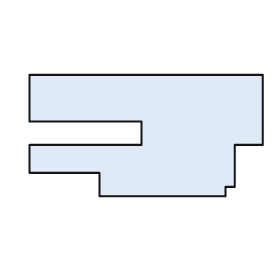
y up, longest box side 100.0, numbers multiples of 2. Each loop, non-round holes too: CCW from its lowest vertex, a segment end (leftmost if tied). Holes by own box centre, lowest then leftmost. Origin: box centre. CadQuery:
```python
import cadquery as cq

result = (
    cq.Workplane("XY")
    .moveTo(-20.0, -26.0)
    .lineTo(34.0, -26.0)
    .lineTo(34.0, -22.0)
    .lineTo(38.0, -22.0)
    .lineTo(38.0, -4.0)
    .lineTo(50.0, -4.0)
    .lineTo(50.0, 26.0)
    .lineTo(-50.0, 26.0)
    .lineTo(-50.0, 6.0)
    .lineTo(-2.0, 6.0)
    .lineTo(-2.0, -4.0)
    .lineTo(-50.0, -4.0)
    .lineTo(-50.0, -16.0)
    .lineTo(-20.0, -16.0)
    .close()
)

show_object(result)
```